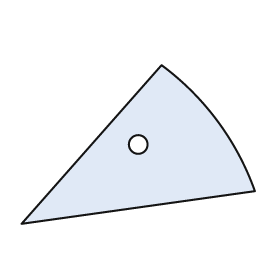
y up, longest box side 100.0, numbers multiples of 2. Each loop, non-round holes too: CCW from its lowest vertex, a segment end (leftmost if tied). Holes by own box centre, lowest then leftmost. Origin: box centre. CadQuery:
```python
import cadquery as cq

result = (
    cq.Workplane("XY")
    .moveTo(-50.0, -34.0)
    .lineTo(50.0, -20.0)
    .threePointArc((34.0, 10.0), (10.0, 34.0))
    .close()
    .moveTo(0.0, 0.0)
    .circle(4.0)
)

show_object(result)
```